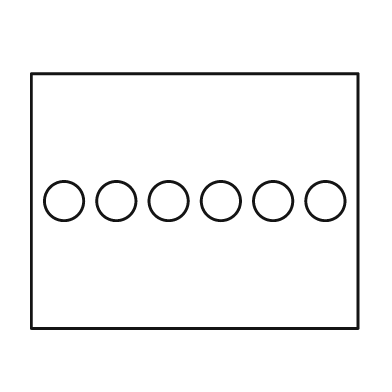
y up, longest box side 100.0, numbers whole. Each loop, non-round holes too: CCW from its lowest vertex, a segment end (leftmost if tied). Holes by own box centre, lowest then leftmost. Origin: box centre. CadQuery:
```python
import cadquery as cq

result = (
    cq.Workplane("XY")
    .moveTo(-50.0, -39.0)
    .lineTo(50.0, -39.0)
    .lineTo(50.0, 39.0)
    .lineTo(-50.0, 39.0)
    .close()
    .moveTo(-40.0, 0.0)
    .circle(6.0)
    .moveTo(-24.0, 0.0)
    .circle(6.0)
    .moveTo(-8.0, 0.0)
    .circle(6.0)
    .moveTo(8.0, 0.0)
    .circle(6.0)
    .moveTo(24.0, 0.0)
    .circle(6.0)
    .moveTo(40.0, 0.0)
    .circle(6.0)
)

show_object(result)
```